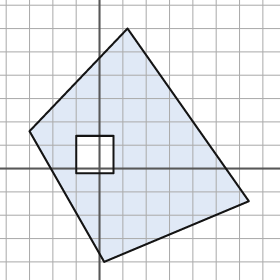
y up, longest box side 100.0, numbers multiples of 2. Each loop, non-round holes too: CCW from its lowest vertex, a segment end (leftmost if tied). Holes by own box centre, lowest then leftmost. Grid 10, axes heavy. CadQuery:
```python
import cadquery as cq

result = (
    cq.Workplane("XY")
    .moveTo(2.0, -40.0)
    .lineTo(64.0, -14.0)
    .lineTo(12.0, 60.0)
    .lineTo(-30.0, 16.0)
    .close()
    .moveTo(-10.0, -2.0)
    .lineTo(6.0, -2.0)
    .lineTo(6.0, 14.0)
    .lineTo(-10.0, 14.0)
    .close()
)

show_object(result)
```